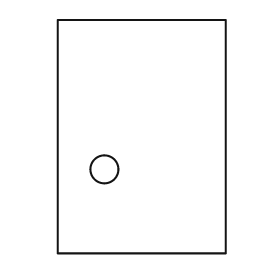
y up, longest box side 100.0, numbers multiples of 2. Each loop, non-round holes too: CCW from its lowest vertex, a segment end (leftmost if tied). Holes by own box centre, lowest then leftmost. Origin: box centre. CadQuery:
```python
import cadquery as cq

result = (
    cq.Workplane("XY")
    .moveTo(-36.0, -50.0)
    .lineTo(36.0, -50.0)
    .lineTo(36.0, 50.0)
    .lineTo(-36.0, 50.0)
    .close()
    .moveTo(-16.0, -14.0)
    .circle(6.0)
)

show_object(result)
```